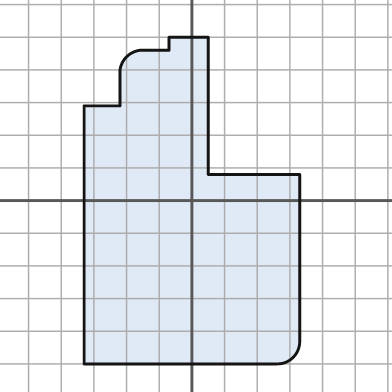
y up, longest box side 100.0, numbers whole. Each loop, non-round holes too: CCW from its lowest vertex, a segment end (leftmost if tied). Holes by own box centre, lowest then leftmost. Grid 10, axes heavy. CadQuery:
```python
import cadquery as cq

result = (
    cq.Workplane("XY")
    .moveTo(-33.0, -50.0)
    .lineTo(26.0, -50.0)
    .threePointArc((31.0, -48.0), (33.0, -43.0))
    .lineTo(33.0, 8.0)
    .lineTo(5.0, 8.0)
    .lineTo(5.0, 50.0)
    .lineTo(-7.0, 50.0)
    .lineTo(-7.0, 46.0)
    .lineTo(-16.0, 46.0)
    .threePointArc((-20.0, 44.0), (-22.0, 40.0))
    .lineTo(-22.0, 29.0)
    .lineTo(-33.0, 29.0)
    .close()
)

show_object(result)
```